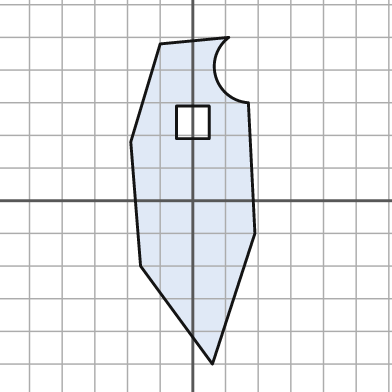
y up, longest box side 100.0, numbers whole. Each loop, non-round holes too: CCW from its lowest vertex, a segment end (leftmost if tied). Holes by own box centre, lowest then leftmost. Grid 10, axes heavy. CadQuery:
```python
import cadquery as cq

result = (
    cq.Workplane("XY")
    .moveTo(6.0, -50.0)
    .lineTo(19.0, -10.0)
    .lineTo(17.0, 30.0)
    .threePointArc((7.0, 38.0), (11.0, 50.0))
    .lineTo(-10.0, 48.0)
    .lineTo(-19.0, 18.0)
    .lineTo(-16.0, -20.0)
    .close()
    .moveTo(-5.0, 19.0)
    .lineTo(5.0, 19.0)
    .lineTo(5.0, 29.0)
    .lineTo(-5.0, 29.0)
    .close()
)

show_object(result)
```